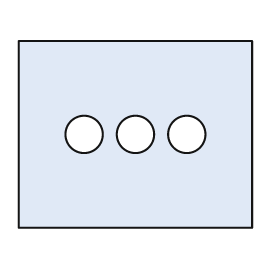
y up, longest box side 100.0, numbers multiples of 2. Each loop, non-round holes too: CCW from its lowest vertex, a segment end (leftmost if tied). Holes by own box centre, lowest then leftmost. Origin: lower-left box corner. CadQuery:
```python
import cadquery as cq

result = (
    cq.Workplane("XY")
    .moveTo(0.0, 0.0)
    .lineTo(100.0, 0.0)
    .lineTo(100.0, 80.0)
    .lineTo(0.0, 80.0)
    .close()
    .moveTo(28.0, 40.0)
    .circle(8.0)
    .moveTo(50.0, 40.0)
    .circle(8.0)
    .moveTo(72.0, 40.0)
    .circle(8.0)
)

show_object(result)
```